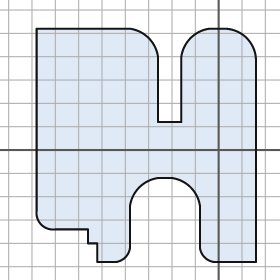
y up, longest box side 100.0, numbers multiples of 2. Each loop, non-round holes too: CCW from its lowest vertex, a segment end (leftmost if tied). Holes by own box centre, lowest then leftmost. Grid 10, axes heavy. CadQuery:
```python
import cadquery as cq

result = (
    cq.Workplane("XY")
    .moveTo(-52.0, -48.0)
    .lineTo(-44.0, -48.0)
    .threePointArc((-40.0, -46.0), (-38.0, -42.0))
    .lineTo(-38.0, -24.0)
    .threePointArc((-34.0, -16.0), (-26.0, -12.0))
    .lineTo(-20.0, -12.0)
    .threePointArc((-12.0, -16.0), (-8.0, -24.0))
    .lineTo(-8.0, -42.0)
    .threePointArc((-6.0, -46.0), (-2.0, -48.0))
    .lineTo(16.0, -48.0)
    .lineTo(16.0, 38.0)
    .threePointArc((12.0, 48.0), (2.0, 52.0))
    .lineTo(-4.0, 52.0)
    .threePointArc((-12.0, 48.0), (-16.0, 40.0))
    .lineTo(-16.0, 12.0)
    .lineTo(-26.0, 12.0)
    .lineTo(-26.0, 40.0)
    .threePointArc((-30.0, 48.0), (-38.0, 52.0))
    .lineTo(-78.0, 52.0)
    .lineTo(-78.0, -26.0)
    .threePointArc((-76.0, -32.0), (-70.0, -34.0))
    .lineTo(-56.0, -34.0)
    .lineTo(-56.0, -40.0)
    .lineTo(-52.0, -40.0)
    .close()
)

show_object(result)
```